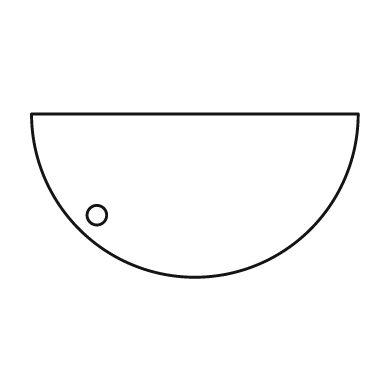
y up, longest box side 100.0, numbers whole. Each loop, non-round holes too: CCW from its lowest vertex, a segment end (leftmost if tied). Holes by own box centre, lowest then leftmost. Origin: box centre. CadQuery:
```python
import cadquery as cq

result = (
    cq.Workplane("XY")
    .moveTo(-50.0, 25.0)
    .threePointArc((0.0, -25.0), (50.0, 25.0))
    .close()
    .moveTo(-30.0, -6.0)
    .circle(3.0)
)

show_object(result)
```